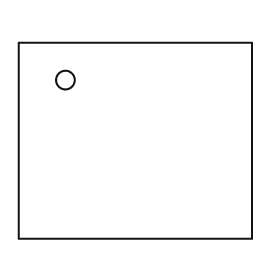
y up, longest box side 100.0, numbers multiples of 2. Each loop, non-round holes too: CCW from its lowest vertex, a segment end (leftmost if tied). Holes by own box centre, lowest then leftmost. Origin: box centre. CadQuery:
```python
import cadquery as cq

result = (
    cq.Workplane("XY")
    .moveTo(-50.0, -42.0)
    .lineTo(50.0, -42.0)
    .lineTo(50.0, 42.0)
    .lineTo(-50.0, 42.0)
    .close()
    .moveTo(-30.0, 26.0)
    .circle(4.0)
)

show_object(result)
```